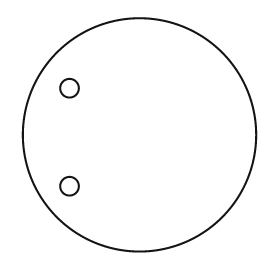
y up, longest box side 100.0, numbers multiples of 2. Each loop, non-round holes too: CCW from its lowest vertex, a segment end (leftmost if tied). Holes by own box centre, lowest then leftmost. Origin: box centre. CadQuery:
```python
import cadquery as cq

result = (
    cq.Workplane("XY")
    .moveTo(0.0, 0.0)
    .circle(50.0)
    .moveTo(-30.0, -22.0)
    .circle(4.0)
    .moveTo(-30.0, 20.0)
    .circle(4.0)
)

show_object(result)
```